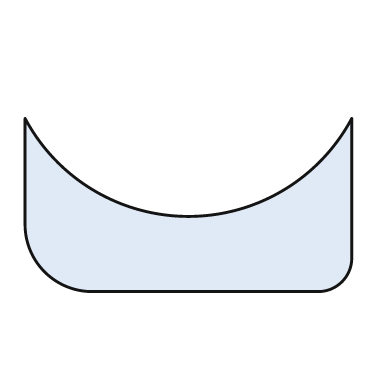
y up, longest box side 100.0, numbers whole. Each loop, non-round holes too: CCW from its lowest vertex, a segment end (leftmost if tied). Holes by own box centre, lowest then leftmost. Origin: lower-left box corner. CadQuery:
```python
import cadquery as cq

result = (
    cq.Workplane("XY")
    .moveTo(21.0, 0.0)
    .lineTo(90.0, 0.0)
    .threePointArc((97.0, 3.0), (100.0, 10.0))
    .lineTo(100.0, 53.0)
    .threePointArc((50.0, 23.0), (0.0, 53.0))
    .lineTo(0.0, 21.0)
    .threePointArc((6.0, 6.0), (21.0, 0.0))
    .close()
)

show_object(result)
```